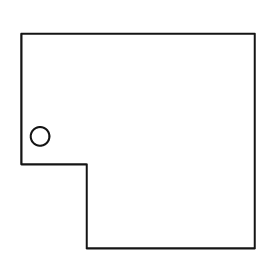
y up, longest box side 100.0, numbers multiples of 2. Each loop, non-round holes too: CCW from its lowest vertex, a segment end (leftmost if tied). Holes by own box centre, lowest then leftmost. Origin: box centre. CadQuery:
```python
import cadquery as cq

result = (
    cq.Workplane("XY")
    .moveTo(-22.0, -46.0)
    .lineTo(50.0, -46.0)
    .lineTo(50.0, 46.0)
    .lineTo(-50.0, 46.0)
    .lineTo(-50.0, -10.0)
    .lineTo(-22.0, -10.0)
    .close()
    .moveTo(-42.0, 2.0)
    .circle(4.0)
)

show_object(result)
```